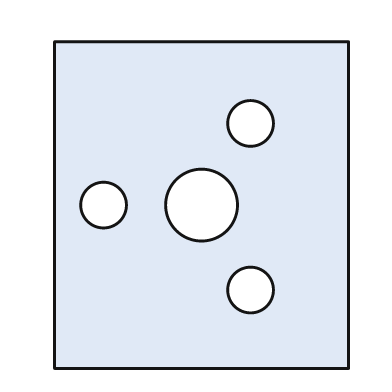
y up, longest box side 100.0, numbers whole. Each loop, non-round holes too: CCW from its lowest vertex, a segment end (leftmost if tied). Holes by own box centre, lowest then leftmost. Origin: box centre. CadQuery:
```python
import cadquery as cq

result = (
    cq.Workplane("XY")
    .moveTo(-45.0, -50.0)
    .lineTo(45.0, -50.0)
    .lineTo(45.0, 50.0)
    .lineTo(-45.0, 50.0)
    .close()
    .moveTo(15.0, -26.0)
    .circle(7.0)
    .moveTo(-30.0, 0.0)
    .circle(7.0)
    .moveTo(0.0, 0.0)
    .circle(11.0)
    .moveTo(15.0, 25.0)
    .circle(7.0)
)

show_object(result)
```